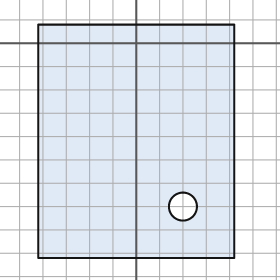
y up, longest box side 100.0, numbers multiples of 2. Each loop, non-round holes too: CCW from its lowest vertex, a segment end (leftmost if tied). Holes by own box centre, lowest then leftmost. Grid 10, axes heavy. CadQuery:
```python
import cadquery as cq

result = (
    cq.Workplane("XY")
    .moveTo(-42.0, -92.0)
    .lineTo(42.0, -92.0)
    .lineTo(42.0, 8.0)
    .lineTo(-42.0, 8.0)
    .close()
    .moveTo(20.0, -70.0)
    .circle(6.0)
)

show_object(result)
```